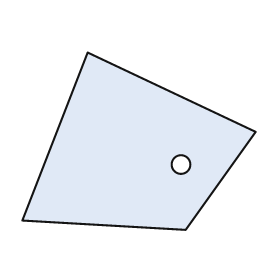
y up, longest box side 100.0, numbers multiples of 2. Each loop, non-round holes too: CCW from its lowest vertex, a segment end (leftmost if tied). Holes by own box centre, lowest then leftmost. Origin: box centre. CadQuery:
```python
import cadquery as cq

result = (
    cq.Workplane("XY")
    .moveTo(20.0, -38.0)
    .lineTo(50.0, 4.0)
    .lineTo(-22.0, 38.0)
    .lineTo(-50.0, -34.0)
    .close()
    .moveTo(18.0, -10.0)
    .circle(4.0)
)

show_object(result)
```